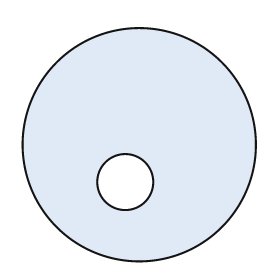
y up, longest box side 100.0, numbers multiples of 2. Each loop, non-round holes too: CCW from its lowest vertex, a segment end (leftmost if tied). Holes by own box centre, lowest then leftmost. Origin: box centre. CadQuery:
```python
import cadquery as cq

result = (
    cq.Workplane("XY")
    .moveTo(0.0, 0.0)
    .circle(50.0)
    .moveTo(-6.0, -16.0)
    .circle(12.0)
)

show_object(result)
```